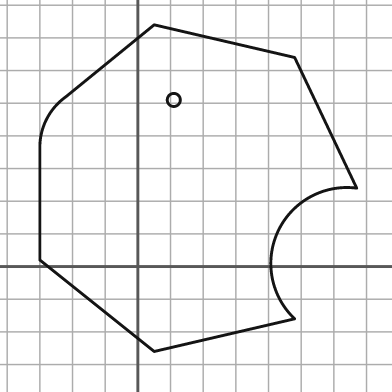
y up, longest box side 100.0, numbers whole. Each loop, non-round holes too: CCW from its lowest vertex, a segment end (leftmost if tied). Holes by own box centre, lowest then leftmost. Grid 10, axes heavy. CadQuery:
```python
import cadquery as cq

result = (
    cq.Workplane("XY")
    .moveTo(5.0, -26.0)
    .lineTo(48.0, -16.0)
    .threePointArc((43.0, 11.0), (67.0, 24.0))
    .lineTo(48.0, 64.0)
    .lineTo(5.0, 74.0)
    .lineTo(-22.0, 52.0)
    .threePointArc((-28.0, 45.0), (-30.0, 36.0))
    .lineTo(-30.0, 2.0)
    .close()
    .moveTo(11.0, 51.0)
    .circle(2.0)
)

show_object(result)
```